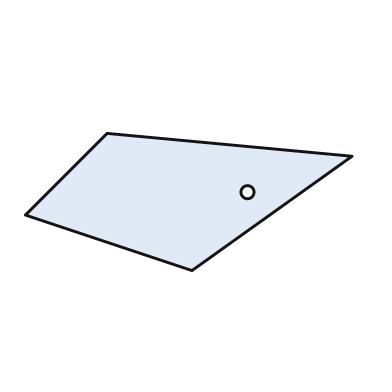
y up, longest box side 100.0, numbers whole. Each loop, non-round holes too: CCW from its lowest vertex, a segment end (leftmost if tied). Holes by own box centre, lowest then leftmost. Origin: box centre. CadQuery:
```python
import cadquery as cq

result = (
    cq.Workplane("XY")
    .moveTo(1.0, -21.0)
    .lineTo(50.0, 14.0)
    .lineTo(-25.0, 21.0)
    .lineTo(-50.0, -4.0)
    .close()
    .moveTo(18.0, 3.0)
    .circle(2.0)
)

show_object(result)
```